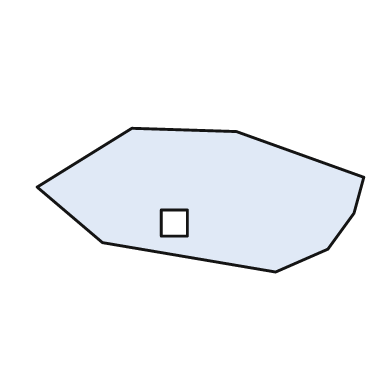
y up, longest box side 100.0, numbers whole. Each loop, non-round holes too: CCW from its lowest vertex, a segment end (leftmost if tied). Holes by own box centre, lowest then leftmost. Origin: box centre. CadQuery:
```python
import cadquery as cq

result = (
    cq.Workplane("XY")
    .moveTo(23.0, -22.0)
    .lineTo(39.0, -15.0)
    .lineTo(47.0, -4.0)
    .lineTo(50.0, 7.0)
    .lineTo(11.0, 21.0)
    .lineTo(-21.0, 22.0)
    .lineTo(-50.0, 4.0)
    .lineTo(-30.0, -13.0)
    .close()
    .moveTo(-12.0, -11.0)
    .lineTo(-4.0, -11.0)
    .lineTo(-4.0, -3.0)
    .lineTo(-12.0, -3.0)
    .close()
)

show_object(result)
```